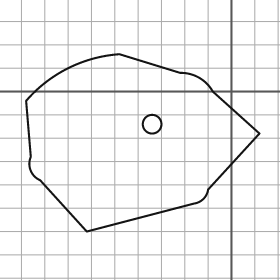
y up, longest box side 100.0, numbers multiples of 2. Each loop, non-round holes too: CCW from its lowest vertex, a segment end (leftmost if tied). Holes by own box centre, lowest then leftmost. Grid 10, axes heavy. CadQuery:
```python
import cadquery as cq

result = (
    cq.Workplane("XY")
    .moveTo(-62.0, -60.0)
    .lineTo(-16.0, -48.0)
    .threePointArc((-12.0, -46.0), (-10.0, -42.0))
    .lineTo(12.0, -18.0)
    .lineTo(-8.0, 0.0)
    .threePointArc((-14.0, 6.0), (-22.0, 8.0))
    .lineTo(-48.0, 16.0)
    .threePointArc((-70.0, 10.0), (-88.0, -4.0))
    .lineTo(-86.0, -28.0)
    .threePointArc((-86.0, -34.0), (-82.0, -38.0))
    .close()
    .moveTo(-34.0, -14.0)
    .circle(4.0)
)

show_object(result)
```